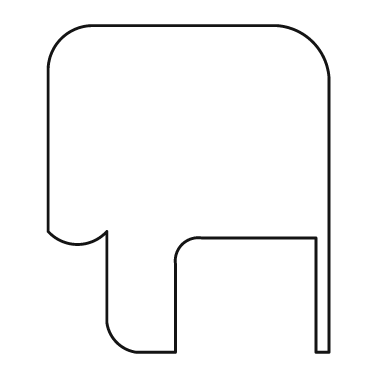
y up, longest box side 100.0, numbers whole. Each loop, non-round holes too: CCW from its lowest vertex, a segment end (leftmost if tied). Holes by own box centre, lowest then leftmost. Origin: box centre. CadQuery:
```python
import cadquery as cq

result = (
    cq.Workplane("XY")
    .moveTo(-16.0, -50.0)
    .lineTo(-4.0, -50.0)
    .lineTo(-4.0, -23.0)
    .threePointArc((-2.0, -17.0), (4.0, -15.0))
    .lineTo(39.0, -15.0)
    .lineTo(39.0, -50.0)
    .lineTo(43.0, -50.0)
    .lineTo(43.0, 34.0)
    .threePointArc((38.0, 45.0), (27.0, 50.0))
    .lineTo(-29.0, 50.0)
    .threePointArc((-39.0, 46.0), (-43.0, 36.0))
    .lineTo(-43.0, -13.0)
    .threePointArc((-34.0, -17.0), (-25.0, -13.0))
    .lineTo(-25.0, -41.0)
    .threePointArc((-22.0, -47.0), (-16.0, -50.0))
    .close()
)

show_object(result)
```